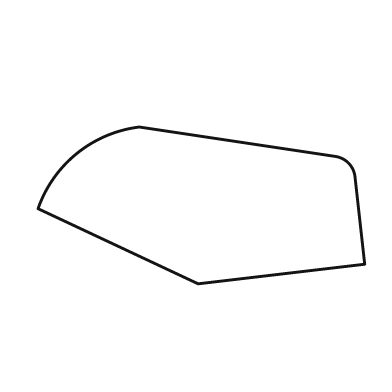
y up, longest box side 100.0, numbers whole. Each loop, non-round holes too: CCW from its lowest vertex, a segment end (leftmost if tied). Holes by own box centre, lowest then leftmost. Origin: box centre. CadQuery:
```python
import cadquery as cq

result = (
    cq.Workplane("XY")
    .moveTo(-1.0, -24.0)
    .lineTo(50.0, -18.0)
    .lineTo(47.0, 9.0)
    .threePointArc((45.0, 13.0), (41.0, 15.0))
    .lineTo(-19.0, 24.0)
    .threePointArc((-38.0, 16.0), (-50.0, -1.0))
    .close()
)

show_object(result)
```